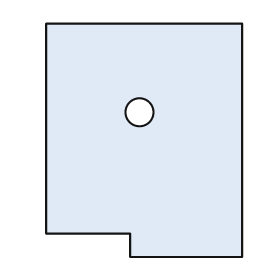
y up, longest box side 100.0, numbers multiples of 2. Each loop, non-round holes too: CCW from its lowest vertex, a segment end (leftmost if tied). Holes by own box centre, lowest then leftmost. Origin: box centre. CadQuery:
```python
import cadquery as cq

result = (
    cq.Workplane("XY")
    .moveTo(-6.0, -50.0)
    .lineTo(42.0, -50.0)
    .lineTo(42.0, 50.0)
    .lineTo(-42.0, 50.0)
    .lineTo(-42.0, -40.0)
    .lineTo(-6.0, -40.0)
    .close()
    .moveTo(-2.0, 12.0)
    .circle(6.0)
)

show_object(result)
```